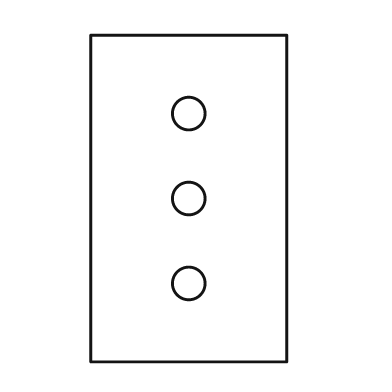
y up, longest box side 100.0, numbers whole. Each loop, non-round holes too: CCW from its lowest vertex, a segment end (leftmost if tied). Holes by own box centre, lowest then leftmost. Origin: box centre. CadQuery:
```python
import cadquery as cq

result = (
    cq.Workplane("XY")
    .moveTo(-30.0, -50.0)
    .lineTo(30.0, -50.0)
    .lineTo(30.0, 50.0)
    .lineTo(-30.0, 50.0)
    .close()
    .moveTo(0.0, -26.0)
    .circle(5.0)
    .moveTo(0.0, 0.0)
    .circle(5.0)
    .moveTo(0.0, 26.0)
    .circle(5.0)
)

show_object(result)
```